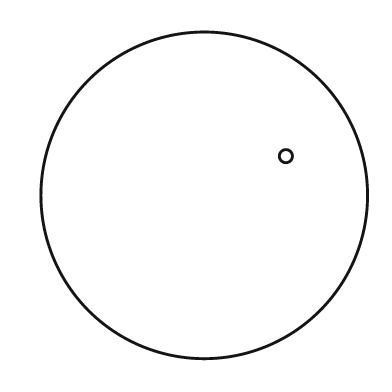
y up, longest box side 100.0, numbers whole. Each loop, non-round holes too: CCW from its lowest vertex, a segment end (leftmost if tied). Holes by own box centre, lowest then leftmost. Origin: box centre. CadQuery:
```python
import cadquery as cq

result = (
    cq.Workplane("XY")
    .moveTo(0.0, 0.0)
    .circle(50.0)
    .moveTo(25.0, 12.0)
    .circle(2.0)
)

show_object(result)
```